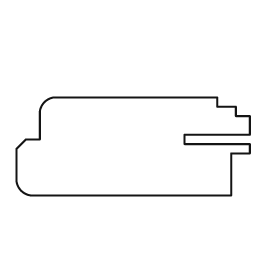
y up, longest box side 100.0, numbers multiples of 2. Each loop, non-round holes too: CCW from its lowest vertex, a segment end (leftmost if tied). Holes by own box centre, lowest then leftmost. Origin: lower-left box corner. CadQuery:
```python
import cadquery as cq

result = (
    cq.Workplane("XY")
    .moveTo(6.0, 0.0)
    .lineTo(92.0, 0.0)
    .lineTo(92.0, 18.0)
    .lineTo(100.0, 18.0)
    .lineTo(100.0, 22.0)
    .lineTo(72.0, 22.0)
    .lineTo(72.0, 26.0)
    .lineTo(100.0, 26.0)
    .lineTo(100.0, 34.0)
    .lineTo(94.0, 34.0)
    .lineTo(94.0, 38.0)
    .lineTo(86.0, 38.0)
    .lineTo(86.0, 42.0)
    .lineTo(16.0, 42.0)
    .threePointArc((12.0, 40.0), (10.0, 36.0))
    .lineTo(10.0, 24.0)
    .lineTo(4.0, 24.0)
    .lineTo(0.0, 20.0)
    .lineTo(0.0, 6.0)
    .threePointArc((2.0, 2.0), (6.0, 0.0))
    .close()
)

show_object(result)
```